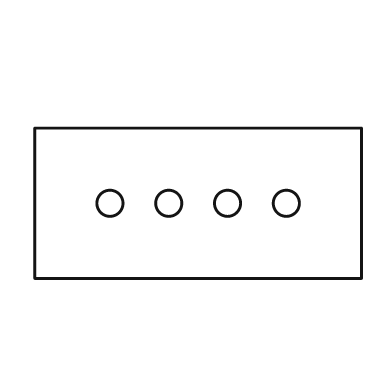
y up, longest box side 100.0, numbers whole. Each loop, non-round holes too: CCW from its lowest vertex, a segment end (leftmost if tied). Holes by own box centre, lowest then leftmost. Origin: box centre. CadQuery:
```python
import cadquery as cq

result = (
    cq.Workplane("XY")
    .moveTo(-50.0, -23.0)
    .lineTo(50.0, -23.0)
    .lineTo(50.0, 23.0)
    .lineTo(-50.0, 23.0)
    .close()
    .moveTo(-27.0, 0.0)
    .circle(4.0)
    .moveTo(-9.0, 0.0)
    .circle(4.0)
    .moveTo(9.0, 0.0)
    .circle(4.0)
    .moveTo(27.0, 0.0)
    .circle(4.0)
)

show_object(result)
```